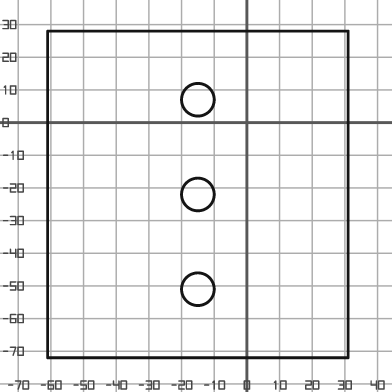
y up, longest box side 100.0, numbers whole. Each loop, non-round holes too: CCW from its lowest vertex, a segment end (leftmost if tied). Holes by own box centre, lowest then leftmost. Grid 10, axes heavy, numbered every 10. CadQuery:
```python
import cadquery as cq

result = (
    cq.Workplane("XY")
    .moveTo(-61.0, -72.0)
    .lineTo(31.0, -72.0)
    .lineTo(31.0, 28.0)
    .lineTo(-61.0, 28.0)
    .close()
    .moveTo(-15.0, -51.0)
    .circle(5.0)
    .moveTo(-15.0, -22.0)
    .circle(5.0)
    .moveTo(-15.0, 7.0)
    .circle(5.0)
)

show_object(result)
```